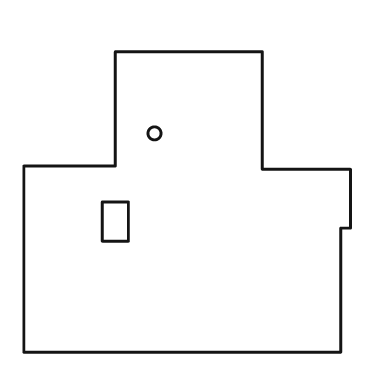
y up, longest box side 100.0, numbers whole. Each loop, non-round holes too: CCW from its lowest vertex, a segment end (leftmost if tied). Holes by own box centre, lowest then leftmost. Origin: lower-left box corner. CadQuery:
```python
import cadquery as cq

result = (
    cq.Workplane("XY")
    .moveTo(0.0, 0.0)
    .lineTo(97.0, 0.0)
    .lineTo(97.0, 38.0)
    .lineTo(100.0, 38.0)
    .lineTo(100.0, 56.0)
    .lineTo(73.0, 56.0)
    .lineTo(73.0, 92.0)
    .lineTo(28.0, 92.0)
    .lineTo(28.0, 57.0)
    .lineTo(0.0, 57.0)
    .close()
    .moveTo(24.0, 34.0)
    .lineTo(32.0, 34.0)
    .lineTo(32.0, 46.0)
    .lineTo(24.0, 46.0)
    .close()
    .moveTo(40.0, 67.0)
    .circle(2.0)
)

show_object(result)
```